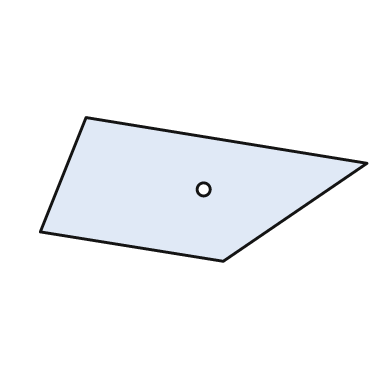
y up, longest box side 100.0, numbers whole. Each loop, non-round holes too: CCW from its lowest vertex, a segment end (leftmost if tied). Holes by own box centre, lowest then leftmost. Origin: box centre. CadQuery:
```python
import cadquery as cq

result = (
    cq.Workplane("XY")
    .moveTo(6.0, -22.0)
    .lineTo(50.0, 8.0)
    .lineTo(-36.0, 22.0)
    .lineTo(-50.0, -13.0)
    .close()
    .moveTo(0.0, 0.0)
    .circle(2.0)
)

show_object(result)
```